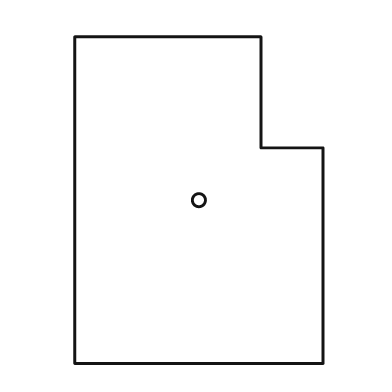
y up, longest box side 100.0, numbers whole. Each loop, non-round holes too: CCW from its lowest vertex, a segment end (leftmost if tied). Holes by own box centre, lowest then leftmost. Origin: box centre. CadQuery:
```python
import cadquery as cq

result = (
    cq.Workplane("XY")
    .moveTo(-38.0, -50.0)
    .lineTo(38.0, -50.0)
    .lineTo(38.0, 16.0)
    .lineTo(19.0, 16.0)
    .lineTo(19.0, 50.0)
    .lineTo(-38.0, 50.0)
    .close()
    .moveTo(0.0, 0.0)
    .circle(2.0)
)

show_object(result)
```